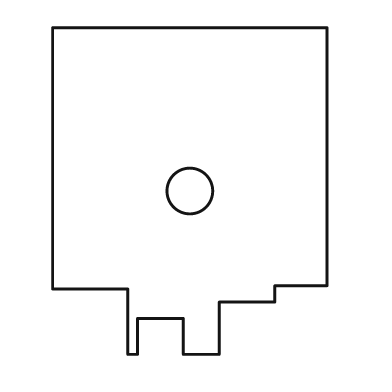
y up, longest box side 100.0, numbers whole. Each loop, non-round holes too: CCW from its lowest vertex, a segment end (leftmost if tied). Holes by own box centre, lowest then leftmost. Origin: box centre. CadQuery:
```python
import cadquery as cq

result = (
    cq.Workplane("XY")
    .moveTo(-19.0, -50.0)
    .lineTo(-16.0, -50.0)
    .lineTo(-16.0, -39.0)
    .lineTo(-2.0, -39.0)
    .lineTo(-2.0, -50.0)
    .lineTo(9.0, -50.0)
    .lineTo(9.0, -34.0)
    .lineTo(26.0, -34.0)
    .lineTo(26.0, -29.0)
    .lineTo(42.0, -29.0)
    .lineTo(42.0, 50.0)
    .lineTo(-42.0, 50.0)
    .lineTo(-42.0, -30.0)
    .lineTo(-19.0, -30.0)
    .close()
    .moveTo(0.0, 0.0)
    .circle(7.0)
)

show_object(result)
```